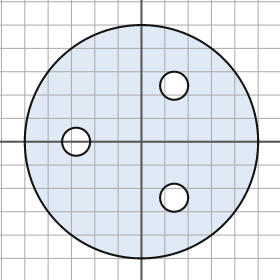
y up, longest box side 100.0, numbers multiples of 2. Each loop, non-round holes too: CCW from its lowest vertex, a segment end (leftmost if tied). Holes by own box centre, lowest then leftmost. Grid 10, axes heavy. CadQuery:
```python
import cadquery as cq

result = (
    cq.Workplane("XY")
    .moveTo(0.0, 0.0)
    .circle(50.0)
    .moveTo(14.0, -24.0)
    .circle(6.0)
    .moveTo(-28.0, 0.0)
    .circle(6.0)
    .moveTo(14.0, 24.0)
    .circle(6.0)
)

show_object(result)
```